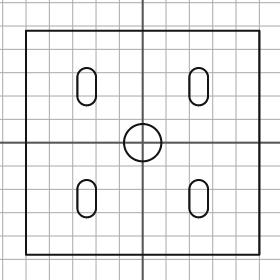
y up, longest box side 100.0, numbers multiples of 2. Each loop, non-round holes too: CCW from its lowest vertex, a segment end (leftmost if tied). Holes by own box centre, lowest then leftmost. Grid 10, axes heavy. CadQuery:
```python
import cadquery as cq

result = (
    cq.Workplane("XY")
    .moveTo(-50.0, -48.0)
    .lineTo(50.0, -48.0)
    .lineTo(50.0, 48.0)
    .lineTo(-50.0, 48.0)
    .close()
    .moveTo(-28.0, -28.0)
    .threePointArc((-24.0, -32.0), (-20.0, -28.0))
    .lineTo(-20.0, -20.0)
    .threePointArc((-24.0, -16.0), (-28.0, -20.0))
    .close()
    .moveTo(20.0, -28.0)
    .threePointArc((24.0, -32.0), (28.0, -28.0))
    .lineTo(28.0, -20.0)
    .threePointArc((24.0, -16.0), (20.0, -20.0))
    .close()
    .moveTo(0.0, 0.0)
    .circle(8.0)
    .moveTo(-28.0, 20.0)
    .threePointArc((-24.0, 16.0), (-20.0, 20.0))
    .lineTo(-20.0, 28.0)
    .threePointArc((-24.0, 32.0), (-28.0, 28.0))
    .close()
    .moveTo(20.0, 20.0)
    .threePointArc((24.0, 16.0), (28.0, 20.0))
    .lineTo(28.0, 28.0)
    .threePointArc((24.0, 32.0), (20.0, 28.0))
    .close()
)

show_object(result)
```